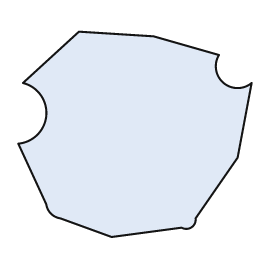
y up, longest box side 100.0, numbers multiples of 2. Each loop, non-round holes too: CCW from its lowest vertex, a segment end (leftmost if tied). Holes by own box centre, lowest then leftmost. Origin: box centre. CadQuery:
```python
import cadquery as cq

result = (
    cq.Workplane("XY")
    .moveTo(-10.0, -44.0)
    .lineTo(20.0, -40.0)
    .threePointArc((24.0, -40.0), (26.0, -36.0))
    .lineTo(44.0, -10.0)
    .lineTo(50.0, 22.0)
    .threePointArc((38.0, 22.0), (36.0, 34.0))
    .lineTo(8.0, 42.0)
    .lineTo(-24.0, 44.0)
    .lineTo(-48.0, 22.0)
    .threePointArc((-38.0, 8.0), (-50.0, -4.0))
    .lineTo(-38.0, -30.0)
    .threePointArc((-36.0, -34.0), (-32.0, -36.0))
    .close()
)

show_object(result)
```